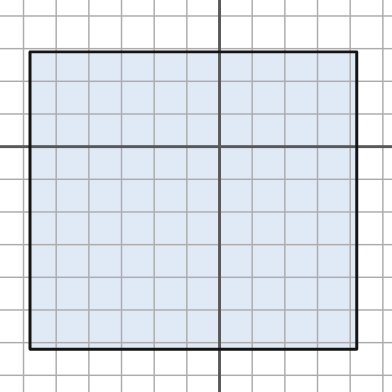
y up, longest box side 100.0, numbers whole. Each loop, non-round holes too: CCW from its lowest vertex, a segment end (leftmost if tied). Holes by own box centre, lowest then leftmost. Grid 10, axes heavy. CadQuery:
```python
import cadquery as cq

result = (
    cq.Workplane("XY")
    .moveTo(-58.0, -62.0)
    .lineTo(42.0, -62.0)
    .lineTo(42.0, 29.0)
    .lineTo(-58.0, 29.0)
    .close()
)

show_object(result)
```